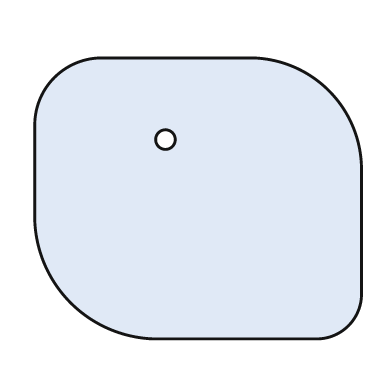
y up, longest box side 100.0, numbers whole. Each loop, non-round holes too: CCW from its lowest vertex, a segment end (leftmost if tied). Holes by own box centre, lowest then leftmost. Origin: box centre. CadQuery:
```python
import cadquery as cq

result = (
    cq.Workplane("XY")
    .moveTo(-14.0, -43.0)
    .lineTo(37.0, -43.0)
    .threePointArc((46.0, -39.0), (50.0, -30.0))
    .lineTo(50.0, 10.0)
    .threePointArc((40.0, 33.0), (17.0, 43.0))
    .lineTo(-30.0, 43.0)
    .threePointArc((-44.0, 37.0), (-50.0, 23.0))
    .lineTo(-50.0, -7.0)
    .threePointArc((-39.0, -32.0), (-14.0, -43.0))
    .close()
    .moveTo(-10.0, 18.0)
    .circle(3.0)
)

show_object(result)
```